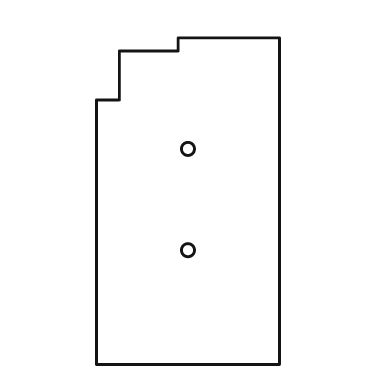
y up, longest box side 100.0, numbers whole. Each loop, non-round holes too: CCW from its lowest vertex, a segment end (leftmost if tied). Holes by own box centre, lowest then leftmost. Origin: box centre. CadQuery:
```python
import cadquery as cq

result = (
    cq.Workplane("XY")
    .moveTo(-28.0, -50.0)
    .lineTo(28.0, -50.0)
    .lineTo(28.0, 50.0)
    .lineTo(-3.0, 50.0)
    .lineTo(-3.0, 46.0)
    .lineTo(-21.0, 46.0)
    .lineTo(-21.0, 31.0)
    .lineTo(-28.0, 31.0)
    .close()
    .moveTo(0.0, -15.0)
    .circle(2.0)
    .moveTo(0.0, 16.0)
    .circle(2.0)
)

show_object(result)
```